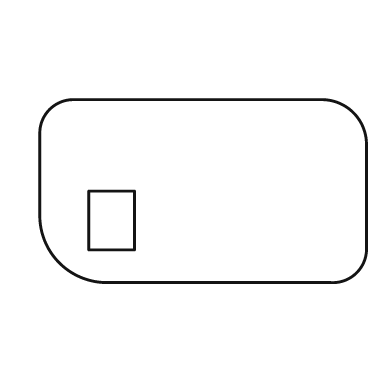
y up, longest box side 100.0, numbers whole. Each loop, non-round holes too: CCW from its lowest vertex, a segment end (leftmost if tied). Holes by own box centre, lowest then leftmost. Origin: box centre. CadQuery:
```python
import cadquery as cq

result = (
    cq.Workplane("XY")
    .moveTo(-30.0, -28.0)
    .lineTo(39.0, -28.0)
    .threePointArc((47.0, -25.0), (50.0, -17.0))
    .lineTo(50.0, 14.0)
    .threePointArc((46.0, 24.0), (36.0, 28.0))
    .lineTo(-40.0, 28.0)
    .threePointArc((-47.0, 25.0), (-50.0, 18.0))
    .lineTo(-50.0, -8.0)
    .threePointArc((-44.0, -22.0), (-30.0, -28.0))
    .close()
    .moveTo(-35.0, -18.0)
    .lineTo(-21.0, -18.0)
    .lineTo(-21.0, 0.0)
    .lineTo(-35.0, 0.0)
    .close()
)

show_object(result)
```